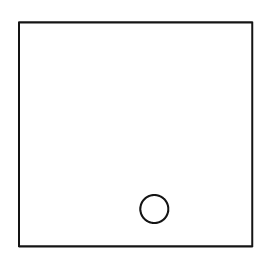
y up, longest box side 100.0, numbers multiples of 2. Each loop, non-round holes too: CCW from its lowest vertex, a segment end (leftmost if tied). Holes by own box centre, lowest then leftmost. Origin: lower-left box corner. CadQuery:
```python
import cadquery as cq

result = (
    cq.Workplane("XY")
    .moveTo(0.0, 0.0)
    .lineTo(100.0, 0.0)
    .lineTo(100.0, 96.0)
    .lineTo(0.0, 96.0)
    .close()
    .moveTo(58.0, 16.0)
    .circle(6.0)
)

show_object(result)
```